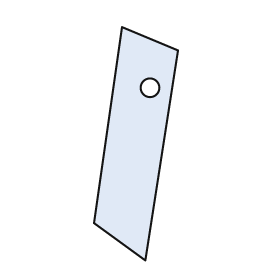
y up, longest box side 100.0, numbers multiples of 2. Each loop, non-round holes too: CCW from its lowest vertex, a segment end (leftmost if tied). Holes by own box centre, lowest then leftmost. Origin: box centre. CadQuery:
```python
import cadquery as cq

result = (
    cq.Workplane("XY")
    .moveTo(4.0, -50.0)
    .lineTo(18.0, 40.0)
    .lineTo(-6.0, 50.0)
    .lineTo(-18.0, -34.0)
    .close()
    .moveTo(6.0, 24.0)
    .circle(4.0)
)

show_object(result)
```